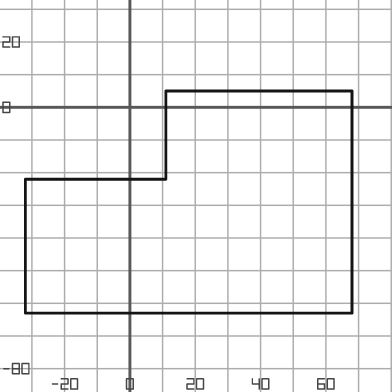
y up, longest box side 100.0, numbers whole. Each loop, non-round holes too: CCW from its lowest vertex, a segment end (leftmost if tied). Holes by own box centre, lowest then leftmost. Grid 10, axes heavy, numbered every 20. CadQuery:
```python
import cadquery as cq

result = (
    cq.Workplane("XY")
    .moveTo(-32.0, -63.0)
    .lineTo(68.0, -63.0)
    .lineTo(68.0, 5.0)
    .lineTo(11.0, 5.0)
    .lineTo(11.0, -22.0)
    .lineTo(-32.0, -22.0)
    .close()
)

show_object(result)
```